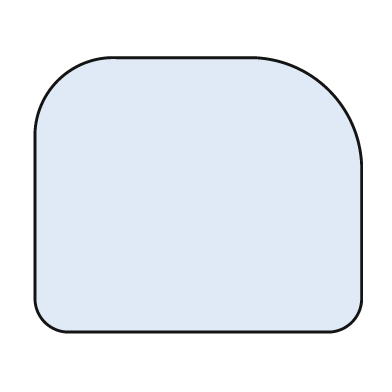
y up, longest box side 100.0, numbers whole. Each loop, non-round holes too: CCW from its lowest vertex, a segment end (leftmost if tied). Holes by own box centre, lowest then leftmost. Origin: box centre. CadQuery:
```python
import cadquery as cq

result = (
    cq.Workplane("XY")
    .moveTo(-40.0, -42.0)
    .lineTo(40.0, -42.0)
    .threePointArc((47.0, -39.0), (50.0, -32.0))
    .lineTo(50.0, 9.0)
    .threePointArc((40.0, 32.0), (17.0, 42.0))
    .lineTo(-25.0, 42.0)
    .threePointArc((-43.0, 35.0), (-50.0, 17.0))
    .lineTo(-50.0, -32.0)
    .threePointArc((-47.0, -39.0), (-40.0, -42.0))
    .close()
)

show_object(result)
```